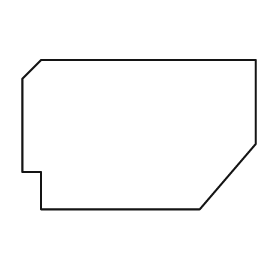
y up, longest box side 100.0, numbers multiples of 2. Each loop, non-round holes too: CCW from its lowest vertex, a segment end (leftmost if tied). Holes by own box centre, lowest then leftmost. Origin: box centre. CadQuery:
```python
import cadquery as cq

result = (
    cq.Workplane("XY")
    .moveTo(-42.0, -32.0)
    .lineTo(26.0, -32.0)
    .lineTo(50.0, -4.0)
    .lineTo(50.0, 32.0)
    .lineTo(-42.0, 32.0)
    .lineTo(-50.0, 24.0)
    .lineTo(-50.0, -16.0)
    .lineTo(-42.0, -16.0)
    .close()
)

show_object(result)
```